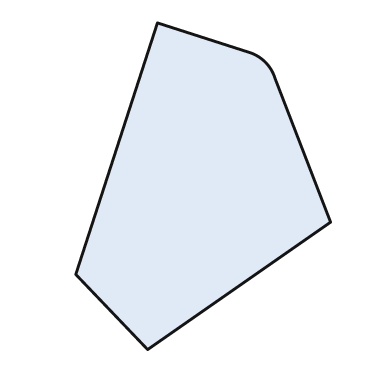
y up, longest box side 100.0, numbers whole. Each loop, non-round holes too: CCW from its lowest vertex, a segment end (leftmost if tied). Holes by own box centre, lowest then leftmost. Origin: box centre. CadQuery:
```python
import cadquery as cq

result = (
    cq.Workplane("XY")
    .moveTo(-17.0, -50.0)
    .lineTo(39.0, -11.0)
    .lineTo(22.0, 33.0)
    .threePointArc((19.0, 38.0), (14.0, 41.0))
    .lineTo(-14.0, 50.0)
    .lineTo(-39.0, -27.0)
    .close()
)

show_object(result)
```